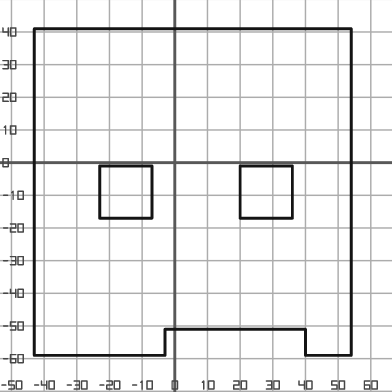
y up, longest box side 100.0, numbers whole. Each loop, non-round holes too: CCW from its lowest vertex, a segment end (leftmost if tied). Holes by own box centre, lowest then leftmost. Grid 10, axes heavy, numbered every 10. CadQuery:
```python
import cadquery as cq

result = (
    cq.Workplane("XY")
    .moveTo(-43.0, -59.0)
    .lineTo(-3.0, -59.0)
    .lineTo(-3.0, -51.0)
    .lineTo(40.0, -51.0)
    .lineTo(40.0, -59.0)
    .lineTo(54.0, -59.0)
    .lineTo(54.0, 41.0)
    .lineTo(-43.0, 41.0)
    .close()
    .moveTo(-23.0, -17.0)
    .lineTo(-7.0, -17.0)
    .lineTo(-7.0, -1.0)
    .lineTo(-23.0, -1.0)
    .close()
    .moveTo(20.0, -17.0)
    .lineTo(36.0, -17.0)
    .lineTo(36.0, -1.0)
    .lineTo(20.0, -1.0)
    .close()
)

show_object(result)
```